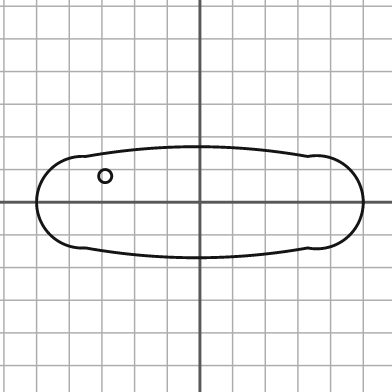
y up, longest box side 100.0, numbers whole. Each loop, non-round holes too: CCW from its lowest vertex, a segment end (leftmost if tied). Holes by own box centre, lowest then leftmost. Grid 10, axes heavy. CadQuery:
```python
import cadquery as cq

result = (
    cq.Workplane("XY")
    .moveTo(-35.0, -14.0)
    .threePointArc((-1.0, -17.0), (33.0, -14.0))
    .threePointArc((50.0, 0.0), (33.0, 14.0))
    .threePointArc((-1.0, 17.0), (-35.0, 14.0))
    .threePointArc((-50.0, 0.0), (-35.0, -14.0))
    .close()
    .moveTo(-29.0, 8.0)
    .circle(2.0)
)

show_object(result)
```